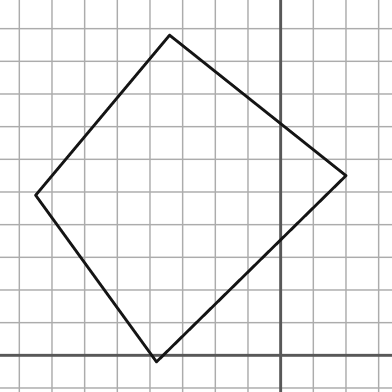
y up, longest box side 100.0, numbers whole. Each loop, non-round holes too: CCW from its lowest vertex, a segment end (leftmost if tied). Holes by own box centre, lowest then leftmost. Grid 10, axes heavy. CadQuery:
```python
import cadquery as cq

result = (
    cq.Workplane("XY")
    .moveTo(-38.0, -2.0)
    .lineTo(20.0, 55.0)
    .lineTo(-34.0, 98.0)
    .lineTo(-75.0, 49.0)
    .close()
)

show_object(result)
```